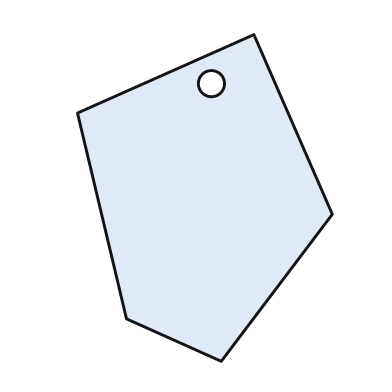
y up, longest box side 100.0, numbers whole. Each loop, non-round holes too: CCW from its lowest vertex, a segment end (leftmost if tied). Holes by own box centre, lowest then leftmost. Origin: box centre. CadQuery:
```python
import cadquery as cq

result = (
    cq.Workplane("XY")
    .moveTo(5.0, -50.0)
    .lineTo(39.0, -5.0)
    .lineTo(15.0, 50.0)
    .lineTo(-39.0, 26.0)
    .lineTo(-24.0, -37.0)
    .close()
    .moveTo(2.0, 35.0)
    .circle(4.0)
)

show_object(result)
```